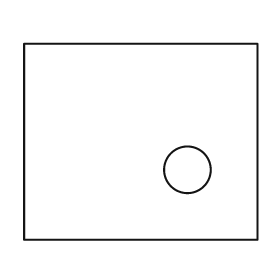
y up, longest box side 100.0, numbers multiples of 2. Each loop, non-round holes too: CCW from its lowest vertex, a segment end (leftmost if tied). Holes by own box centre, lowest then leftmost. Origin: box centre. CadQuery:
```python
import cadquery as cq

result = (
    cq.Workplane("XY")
    .moveTo(-50.0, -42.0)
    .lineTo(50.0, -42.0)
    .lineTo(50.0, 42.0)
    .lineTo(-50.0, 42.0)
    .close()
    .moveTo(20.0, -12.0)
    .circle(10.0)
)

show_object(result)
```